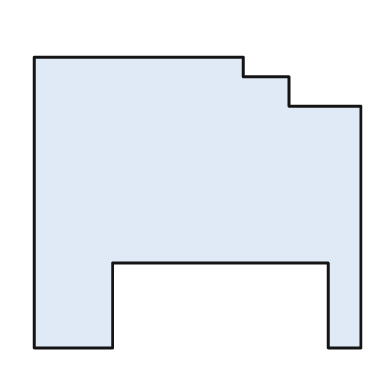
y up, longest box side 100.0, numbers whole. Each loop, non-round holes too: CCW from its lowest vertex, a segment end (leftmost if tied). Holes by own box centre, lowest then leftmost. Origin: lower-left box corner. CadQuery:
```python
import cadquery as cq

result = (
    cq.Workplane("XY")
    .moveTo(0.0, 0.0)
    .lineTo(24.0, 0.0)
    .lineTo(24.0, 26.0)
    .lineTo(90.0, 26.0)
    .lineTo(90.0, 0.0)
    .lineTo(100.0, 0.0)
    .lineTo(100.0, 74.0)
    .lineTo(78.0, 74.0)
    .lineTo(78.0, 83.0)
    .lineTo(64.0, 83.0)
    .lineTo(64.0, 89.0)
    .lineTo(0.0, 89.0)
    .close()
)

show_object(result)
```